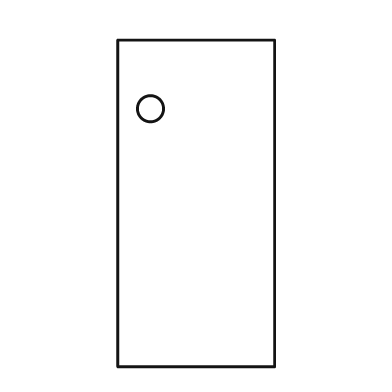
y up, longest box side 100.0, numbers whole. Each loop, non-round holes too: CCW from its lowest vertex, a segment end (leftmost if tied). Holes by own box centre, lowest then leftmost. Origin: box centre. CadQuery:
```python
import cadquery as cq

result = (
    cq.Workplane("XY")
    .moveTo(-24.0, -50.0)
    .lineTo(24.0, -50.0)
    .lineTo(24.0, 50.0)
    .lineTo(-24.0, 50.0)
    .close()
    .moveTo(-14.0, 29.0)
    .circle(4.0)
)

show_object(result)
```